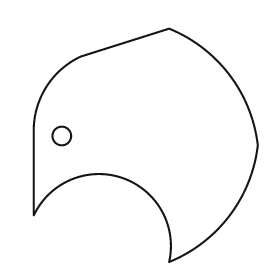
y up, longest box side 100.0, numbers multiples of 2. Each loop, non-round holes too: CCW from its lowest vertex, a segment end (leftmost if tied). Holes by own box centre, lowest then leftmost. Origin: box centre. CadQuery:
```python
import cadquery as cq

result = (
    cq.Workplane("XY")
    .moveTo(10.0, -50.0)
    .threePointArc((36.0, -30.0), (48.0, 0.0))
    .threePointArc((36.0, 30.0), (10.0, 50.0))
    .lineTo(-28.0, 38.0)
    .threePointArc((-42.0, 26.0), (-48.0, 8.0))
    .lineTo(-48.0, -30.0)
    .threePointArc((-10.0, -14.0), (10.0, -50.0))
    .close()
    .moveTo(-36.0, 4.0)
    .circle(4.0)
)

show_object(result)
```